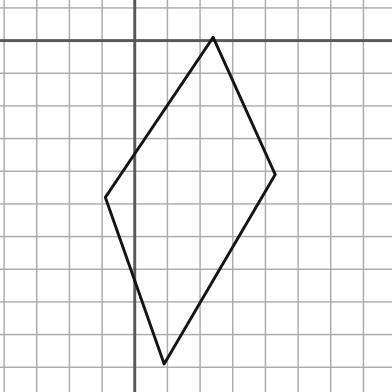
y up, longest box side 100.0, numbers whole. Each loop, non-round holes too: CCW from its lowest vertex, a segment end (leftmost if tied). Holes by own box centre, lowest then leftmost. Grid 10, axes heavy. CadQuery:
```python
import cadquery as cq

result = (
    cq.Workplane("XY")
    .moveTo(9.0, -99.0)
    .lineTo(43.0, -41.0)
    .lineTo(24.0, 1.0)
    .lineTo(-9.0, -48.0)
    .close()
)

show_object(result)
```